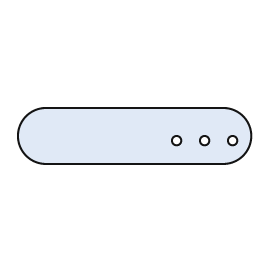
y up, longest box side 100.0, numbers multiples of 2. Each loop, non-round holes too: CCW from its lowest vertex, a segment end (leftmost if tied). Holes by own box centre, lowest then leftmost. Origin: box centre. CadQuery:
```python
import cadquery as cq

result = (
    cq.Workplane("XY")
    .moveTo(-38.0, -12.0)
    .lineTo(38.0, -12.0)
    .threePointArc((50.0, 0.0), (38.0, 12.0))
    .lineTo(-38.0, 12.0)
    .threePointArc((-50.0, 0.0), (-38.0, -12.0))
    .close()
    .moveTo(18.0, -2.0)
    .circle(2.0)
    .moveTo(30.0, -2.0)
    .circle(2.0)
    .moveTo(42.0, -2.0)
    .circle(2.0)
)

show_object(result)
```